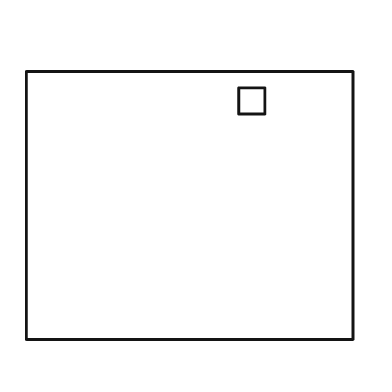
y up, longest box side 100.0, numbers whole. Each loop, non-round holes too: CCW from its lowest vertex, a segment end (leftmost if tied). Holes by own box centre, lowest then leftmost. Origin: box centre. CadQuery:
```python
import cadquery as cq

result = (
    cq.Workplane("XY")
    .moveTo(-50.0, -41.0)
    .lineTo(50.0, -41.0)
    .lineTo(50.0, 41.0)
    .lineTo(-50.0, 41.0)
    .close()
    .moveTo(15.0, 28.0)
    .lineTo(23.0, 28.0)
    .lineTo(23.0, 36.0)
    .lineTo(15.0, 36.0)
    .close()
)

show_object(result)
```